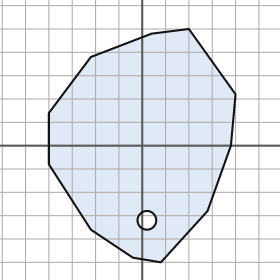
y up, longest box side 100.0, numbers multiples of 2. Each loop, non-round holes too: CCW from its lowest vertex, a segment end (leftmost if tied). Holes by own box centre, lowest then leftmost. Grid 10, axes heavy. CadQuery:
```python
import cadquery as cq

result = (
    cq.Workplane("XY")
    .moveTo(8.0, -50.0)
    .lineTo(28.0, -28.0)
    .lineTo(38.0, 0.0)
    .lineTo(40.0, 22.0)
    .lineTo(20.0, 50.0)
    .lineTo(4.0, 48.0)
    .lineTo(-22.0, 38.0)
    .lineTo(-40.0, 14.0)
    .lineTo(-40.0, -8.0)
    .lineTo(-22.0, -36.0)
    .lineTo(-4.0, -48.0)
    .close()
    .moveTo(2.0, -32.0)
    .circle(4.0)
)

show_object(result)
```